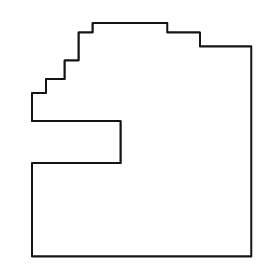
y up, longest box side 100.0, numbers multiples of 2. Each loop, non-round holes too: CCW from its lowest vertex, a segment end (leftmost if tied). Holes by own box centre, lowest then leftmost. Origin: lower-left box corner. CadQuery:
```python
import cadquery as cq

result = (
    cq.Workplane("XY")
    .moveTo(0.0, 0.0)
    .lineTo(94.0, 0.0)
    .lineTo(94.0, 90.0)
    .lineTo(72.0, 90.0)
    .lineTo(72.0, 96.0)
    .lineTo(58.0, 96.0)
    .lineTo(58.0, 100.0)
    .lineTo(26.0, 100.0)
    .lineTo(26.0, 96.0)
    .lineTo(20.0, 96.0)
    .lineTo(20.0, 84.0)
    .lineTo(14.0, 84.0)
    .lineTo(14.0, 76.0)
    .lineTo(6.0, 76.0)
    .lineTo(6.0, 70.0)
    .lineTo(0.0, 70.0)
    .lineTo(0.0, 58.0)
    .lineTo(38.0, 58.0)
    .lineTo(38.0, 40.0)
    .lineTo(0.0, 40.0)
    .close()
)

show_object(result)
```